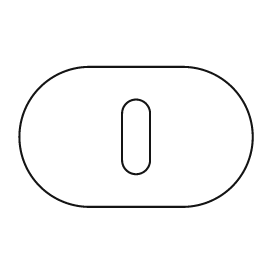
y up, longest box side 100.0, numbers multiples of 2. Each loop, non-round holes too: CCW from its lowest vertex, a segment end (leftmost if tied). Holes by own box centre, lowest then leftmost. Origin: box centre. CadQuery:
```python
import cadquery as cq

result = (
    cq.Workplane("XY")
    .moveTo(-20.0, -30.0)
    .lineTo(20.0, -30.0)
    .threePointArc((50.0, 0.0), (20.0, 30.0))
    .lineTo(-20.0, 30.0)
    .threePointArc((-50.0, 0.0), (-20.0, -30.0))
    .close()
    .moveTo(-6.0, -10.0)
    .threePointArc((0.0, -16.0), (6.0, -10.0))
    .lineTo(6.0, 10.0)
    .threePointArc((0.0, 16.0), (-6.0, 10.0))
    .close()
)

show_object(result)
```